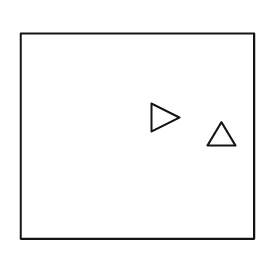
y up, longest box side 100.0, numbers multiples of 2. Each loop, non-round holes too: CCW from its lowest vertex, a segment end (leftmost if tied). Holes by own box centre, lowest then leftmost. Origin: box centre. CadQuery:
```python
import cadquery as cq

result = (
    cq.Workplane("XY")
    .moveTo(-50.0, -44.0)
    .lineTo(50.0, -44.0)
    .lineTo(50.0, 44.0)
    .lineTo(-50.0, 44.0)
    .close()
    .moveTo(30.0, -4.0)
    .lineTo(42.0, -4.0)
    .lineTo(36.0, 6.0)
    .close()
    .moveTo(6.0, 2.0)
    .lineTo(18.0, 8.0)
    .lineTo(6.0, 14.0)
    .close()
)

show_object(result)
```